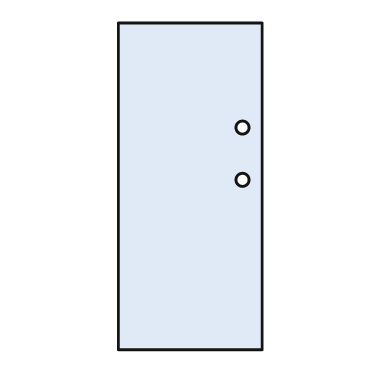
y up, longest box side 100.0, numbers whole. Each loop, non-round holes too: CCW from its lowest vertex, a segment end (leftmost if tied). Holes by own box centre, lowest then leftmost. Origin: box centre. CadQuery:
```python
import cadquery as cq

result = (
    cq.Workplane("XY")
    .moveTo(-22.0, -50.0)
    .lineTo(22.0, -50.0)
    .lineTo(22.0, 50.0)
    .lineTo(-22.0, 50.0)
    .close()
    .moveTo(16.0, 2.0)
    .circle(2.0)
    .moveTo(16.0, 18.0)
    .circle(2.0)
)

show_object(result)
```